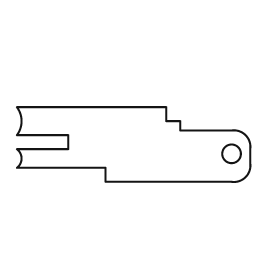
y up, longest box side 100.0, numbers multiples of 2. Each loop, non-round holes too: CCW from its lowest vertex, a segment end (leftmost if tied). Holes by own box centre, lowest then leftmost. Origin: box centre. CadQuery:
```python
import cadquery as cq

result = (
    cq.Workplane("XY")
    .moveTo(-12.0, -16.0)
    .lineTo(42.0, -16.0)
    .threePointArc((48.0, -14.0), (50.0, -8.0))
    .lineTo(50.0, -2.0)
    .threePointArc((48.0, 4.0), (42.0, 6.0))
    .lineTo(20.0, 6.0)
    .lineTo(20.0, 10.0)
    .lineTo(14.0, 10.0)
    .lineTo(14.0, 16.0)
    .lineTo(-50.0, 16.0)
    .threePointArc((-48.0, 10.0), (-50.0, 4.0))
    .lineTo(-28.0, 4.0)
    .lineTo(-28.0, -2.0)
    .lineTo(-50.0, -2.0)
    .threePointArc((-48.0, -6.0), (-50.0, -10.0))
    .lineTo(-12.0, -10.0)
    .close()
    .moveTo(42.0, -4.0)
    .circle(4.0)
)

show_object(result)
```